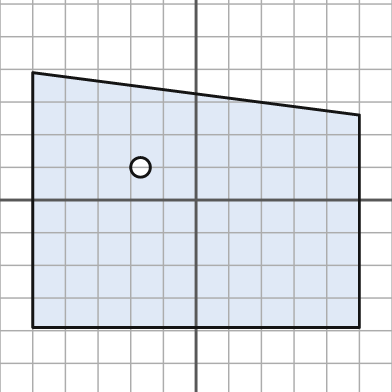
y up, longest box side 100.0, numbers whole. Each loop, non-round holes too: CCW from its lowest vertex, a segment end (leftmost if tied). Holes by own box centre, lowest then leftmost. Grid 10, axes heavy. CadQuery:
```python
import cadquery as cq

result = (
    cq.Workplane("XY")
    .moveTo(-50.0, -39.0)
    .lineTo(50.0, -39.0)
    .lineTo(50.0, 26.0)
    .lineTo(-50.0, 39.0)
    .close()
    .moveTo(-17.0, 10.0)
    .circle(3.0)
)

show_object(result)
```